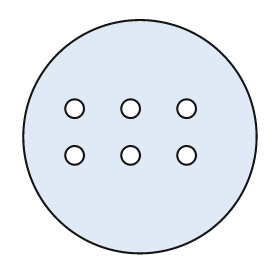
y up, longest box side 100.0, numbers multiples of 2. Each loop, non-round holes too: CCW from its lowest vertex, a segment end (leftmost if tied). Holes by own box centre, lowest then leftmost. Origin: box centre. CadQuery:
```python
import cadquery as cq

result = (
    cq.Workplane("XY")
    .moveTo(0.0, 0.0)
    .circle(50.0)
    .moveTo(-28.0, -8.0)
    .circle(4.0)
    .moveTo(-4.0, -8.0)
    .circle(4.0)
    .moveTo(20.0, -8.0)
    .circle(4.0)
    .moveTo(-28.0, 12.0)
    .circle(4.0)
    .moveTo(-4.0, 12.0)
    .circle(4.0)
    .moveTo(20.0, 12.0)
    .circle(4.0)
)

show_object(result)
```